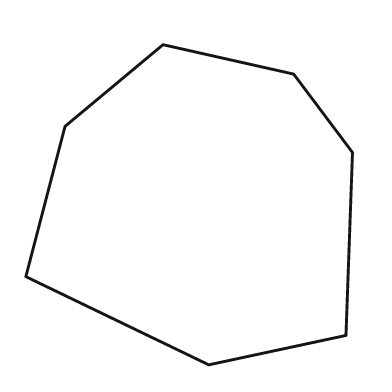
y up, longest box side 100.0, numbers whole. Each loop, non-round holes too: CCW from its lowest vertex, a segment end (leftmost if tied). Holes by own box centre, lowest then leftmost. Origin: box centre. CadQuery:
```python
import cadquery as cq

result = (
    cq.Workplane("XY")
    .moveTo(6.0, -49.0)
    .lineTo(48.0, -40.0)
    .lineTo(50.0, 16.0)
    .lineTo(32.0, 40.0)
    .lineTo(-8.0, 49.0)
    .lineTo(-38.0, 24.0)
    .lineTo(-50.0, -22.0)
    .close()
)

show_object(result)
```